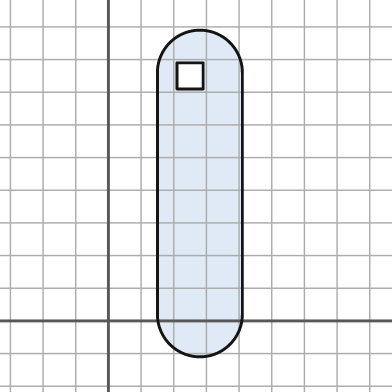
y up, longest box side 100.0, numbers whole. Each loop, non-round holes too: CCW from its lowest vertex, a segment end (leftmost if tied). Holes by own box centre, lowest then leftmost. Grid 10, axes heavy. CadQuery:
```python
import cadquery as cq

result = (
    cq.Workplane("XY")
    .moveTo(15.0, 2.0)
    .threePointArc((28.0, -11.0), (41.0, 2.0))
    .lineTo(41.0, 76.0)
    .threePointArc((28.0, 89.0), (15.0, 76.0))
    .close()
    .moveTo(21.0, 71.0)
    .lineTo(29.0, 71.0)
    .lineTo(29.0, 79.0)
    .lineTo(21.0, 79.0)
    .close()
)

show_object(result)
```